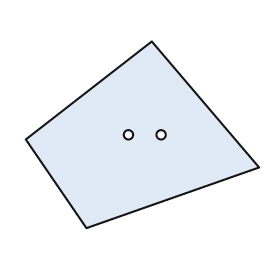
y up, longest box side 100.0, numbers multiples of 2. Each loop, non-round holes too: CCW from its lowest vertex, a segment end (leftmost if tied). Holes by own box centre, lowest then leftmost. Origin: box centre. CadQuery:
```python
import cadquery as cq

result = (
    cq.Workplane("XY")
    .moveTo(-24.0, -40.0)
    .lineTo(50.0, -14.0)
    .lineTo(4.0, 40.0)
    .lineTo(-50.0, -2.0)
    .close()
    .moveTo(-6.0, 0.0)
    .circle(2.0)
    .moveTo(8.0, 0.0)
    .circle(2.0)
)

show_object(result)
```